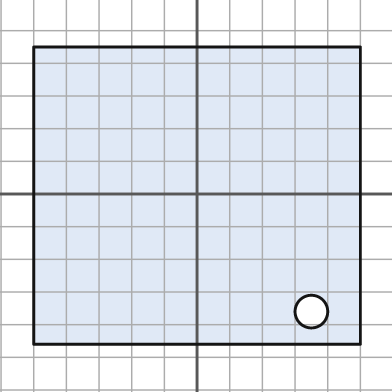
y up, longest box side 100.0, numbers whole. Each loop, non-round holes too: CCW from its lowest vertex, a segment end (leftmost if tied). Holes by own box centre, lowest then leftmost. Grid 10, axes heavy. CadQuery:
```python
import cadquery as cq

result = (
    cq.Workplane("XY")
    .moveTo(-50.0, -46.0)
    .lineTo(50.0, -46.0)
    .lineTo(50.0, 45.0)
    .lineTo(-50.0, 45.0)
    .close()
    .moveTo(35.0, -36.0)
    .circle(5.0)
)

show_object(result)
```